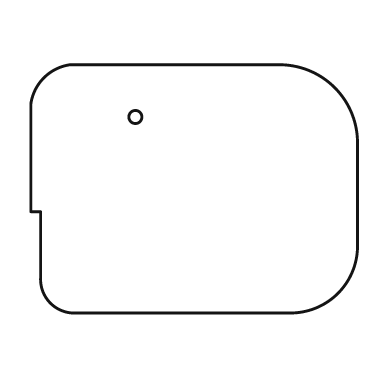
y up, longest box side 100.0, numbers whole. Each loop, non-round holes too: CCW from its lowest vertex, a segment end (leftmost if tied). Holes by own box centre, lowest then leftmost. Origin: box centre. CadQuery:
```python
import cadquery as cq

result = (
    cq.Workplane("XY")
    .moveTo(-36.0, -38.0)
    .lineTo(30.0, -38.0)
    .threePointArc((44.0, -32.0), (50.0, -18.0))
    .lineTo(50.0, 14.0)
    .threePointArc((43.0, 31.0), (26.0, 38.0))
    .lineTo(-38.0, 38.0)
    .threePointArc((-46.0, 34.0), (-50.0, 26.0))
    .lineTo(-50.0, -7.0)
    .lineTo(-47.0, -7.0)
    .lineTo(-47.0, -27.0)
    .threePointArc((-44.0, -35.0), (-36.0, -38.0))
    .close()
    .moveTo(-18.0, 22.0)
    .circle(2.0)
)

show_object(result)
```